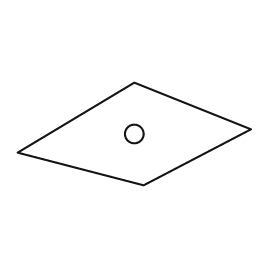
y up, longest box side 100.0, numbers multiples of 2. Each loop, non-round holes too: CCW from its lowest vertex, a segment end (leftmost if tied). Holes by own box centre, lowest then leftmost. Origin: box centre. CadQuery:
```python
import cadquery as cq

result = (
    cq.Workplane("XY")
    .moveTo(4.0, -22.0)
    .lineTo(50.0, 2.0)
    .lineTo(0.0, 22.0)
    .lineTo(-50.0, -8.0)
    .close()
    .moveTo(0.0, 0.0)
    .circle(4.0)
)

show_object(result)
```